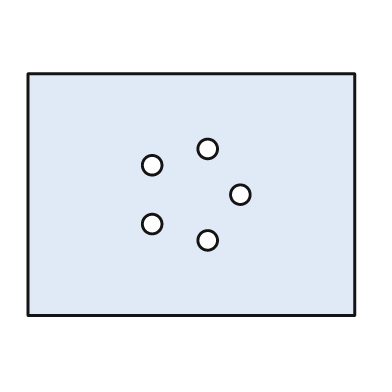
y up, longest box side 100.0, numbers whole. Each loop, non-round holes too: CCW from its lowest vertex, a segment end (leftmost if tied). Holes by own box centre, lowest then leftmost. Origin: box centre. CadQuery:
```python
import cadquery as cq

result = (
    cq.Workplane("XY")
    .moveTo(-50.0, -37.0)
    .lineTo(50.0, -37.0)
    .lineTo(50.0, 37.0)
    .lineTo(-50.0, 37.0)
    .close()
    .moveTo(5.0, -14.0)
    .circle(3.0)
    .moveTo(-12.0, -9.0)
    .circle(3.0)
    .moveTo(15.0, 0.0)
    .circle(3.0)
    .moveTo(-12.0, 9.0)
    .circle(3.0)
    .moveTo(5.0, 14.0)
    .circle(3.0)
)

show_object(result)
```